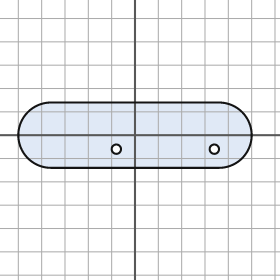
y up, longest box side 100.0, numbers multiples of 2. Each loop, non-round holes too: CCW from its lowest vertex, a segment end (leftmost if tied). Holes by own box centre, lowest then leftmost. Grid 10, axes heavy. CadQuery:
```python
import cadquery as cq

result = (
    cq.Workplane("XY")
    .moveTo(-36.0, -14.0)
    .lineTo(36.0, -14.0)
    .threePointArc((50.0, 0.0), (36.0, 14.0))
    .lineTo(-36.0, 14.0)
    .threePointArc((-50.0, 0.0), (-36.0, -14.0))
    .close()
    .moveTo(-8.0, -6.0)
    .circle(2.0)
    .moveTo(34.0, -6.0)
    .circle(2.0)
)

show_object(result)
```